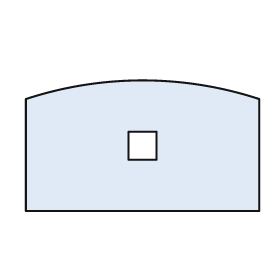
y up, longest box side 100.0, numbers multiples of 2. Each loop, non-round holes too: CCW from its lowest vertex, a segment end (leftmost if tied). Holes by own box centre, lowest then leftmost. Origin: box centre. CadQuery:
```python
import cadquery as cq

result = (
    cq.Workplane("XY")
    .moveTo(-50.0, -28.0)
    .lineTo(50.0, -28.0)
    .lineTo(50.0, 20.0)
    .threePointArc((0.0, 28.0), (-50.0, 20.0))
    .close()
    .moveTo(-6.0, -6.0)
    .lineTo(6.0, -6.0)
    .lineTo(6.0, 6.0)
    .lineTo(-6.0, 6.0)
    .close()
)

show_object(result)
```